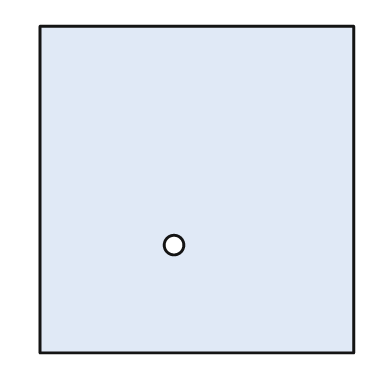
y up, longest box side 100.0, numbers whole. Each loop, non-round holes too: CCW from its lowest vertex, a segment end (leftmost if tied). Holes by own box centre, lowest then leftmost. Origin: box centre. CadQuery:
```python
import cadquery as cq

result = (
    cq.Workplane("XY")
    .moveTo(-48.0, -50.0)
    .lineTo(48.0, -50.0)
    .lineTo(48.0, 50.0)
    .lineTo(-48.0, 50.0)
    .close()
    .moveTo(-7.0, -17.0)
    .circle(3.0)
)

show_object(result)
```